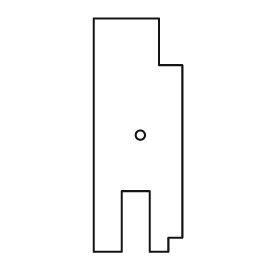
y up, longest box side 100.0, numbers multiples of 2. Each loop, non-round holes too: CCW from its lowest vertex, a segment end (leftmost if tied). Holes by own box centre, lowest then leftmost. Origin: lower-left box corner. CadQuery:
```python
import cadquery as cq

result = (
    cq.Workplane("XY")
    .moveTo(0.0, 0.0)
    .lineTo(12.0, 0.0)
    .lineTo(12.0, 26.0)
    .lineTo(24.0, 26.0)
    .lineTo(24.0, 0.0)
    .lineTo(32.0, 0.0)
    .lineTo(32.0, 6.0)
    .lineTo(38.0, 6.0)
    .lineTo(38.0, 80.0)
    .lineTo(28.0, 80.0)
    .lineTo(28.0, 100.0)
    .lineTo(0.0, 100.0)
    .close()
    .moveTo(20.0, 50.0)
    .circle(2.0)
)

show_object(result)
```